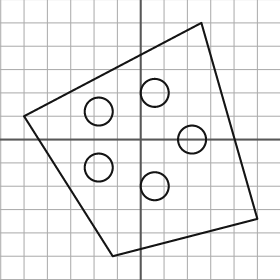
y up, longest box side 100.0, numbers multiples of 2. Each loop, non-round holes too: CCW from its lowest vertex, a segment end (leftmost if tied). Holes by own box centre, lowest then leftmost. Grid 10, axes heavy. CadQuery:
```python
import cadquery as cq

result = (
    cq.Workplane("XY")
    .moveTo(-12.0, -50.0)
    .lineTo(50.0, -34.0)
    .lineTo(26.0, 50.0)
    .lineTo(-50.0, 10.0)
    .close()
    .moveTo(6.0, -20.0)
    .circle(6.0)
    .moveTo(-18.0, -12.0)
    .circle(6.0)
    .moveTo(22.0, 0.0)
    .circle(6.0)
    .moveTo(-18.0, 12.0)
    .circle(6.0)
    .moveTo(6.0, 20.0)
    .circle(6.0)
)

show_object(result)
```